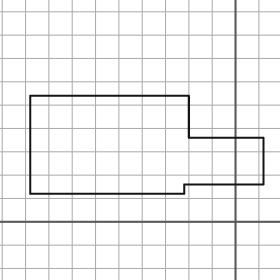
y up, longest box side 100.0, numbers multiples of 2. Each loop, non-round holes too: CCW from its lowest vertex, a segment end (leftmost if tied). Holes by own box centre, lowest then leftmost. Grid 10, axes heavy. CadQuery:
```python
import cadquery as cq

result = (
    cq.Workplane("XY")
    .moveTo(-88.0, 12.0)
    .lineTo(-22.0, 12.0)
    .lineTo(-22.0, 16.0)
    .lineTo(12.0, 16.0)
    .lineTo(12.0, 36.0)
    .lineTo(-20.0, 36.0)
    .lineTo(-20.0, 54.0)
    .lineTo(-88.0, 54.0)
    .close()
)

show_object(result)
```